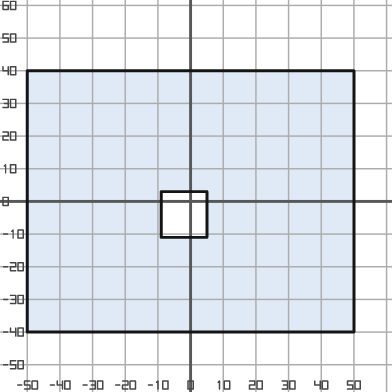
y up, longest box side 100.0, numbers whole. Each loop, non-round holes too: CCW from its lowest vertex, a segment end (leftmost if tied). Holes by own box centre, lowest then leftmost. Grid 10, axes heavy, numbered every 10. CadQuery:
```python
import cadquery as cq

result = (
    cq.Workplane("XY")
    .moveTo(-50.0, -40.0)
    .lineTo(50.0, -40.0)
    .lineTo(50.0, 40.0)
    .lineTo(-50.0, 40.0)
    .close()
    .moveTo(-9.0, -11.0)
    .lineTo(5.0, -11.0)
    .lineTo(5.0, 3.0)
    .lineTo(-9.0, 3.0)
    .close()
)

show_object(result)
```